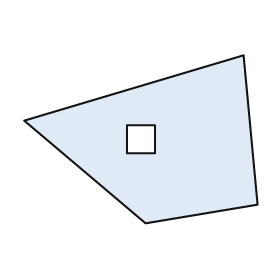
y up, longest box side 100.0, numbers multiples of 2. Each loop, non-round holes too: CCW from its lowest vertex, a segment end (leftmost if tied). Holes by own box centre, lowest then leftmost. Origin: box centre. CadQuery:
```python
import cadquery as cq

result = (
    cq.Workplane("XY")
    .moveTo(2.0, -36.0)
    .lineTo(50.0, -28.0)
    .lineTo(44.0, 36.0)
    .lineTo(-50.0, 8.0)
    .close()
    .moveTo(-6.0, -6.0)
    .lineTo(6.0, -6.0)
    .lineTo(6.0, 6.0)
    .lineTo(-6.0, 6.0)
    .close()
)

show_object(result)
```